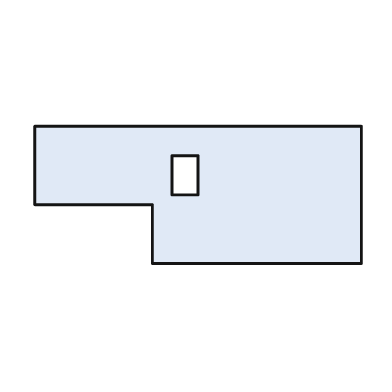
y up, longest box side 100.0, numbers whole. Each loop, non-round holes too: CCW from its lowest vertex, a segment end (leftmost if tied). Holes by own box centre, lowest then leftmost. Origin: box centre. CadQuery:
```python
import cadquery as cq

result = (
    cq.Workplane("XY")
    .moveTo(-14.0, -21.0)
    .lineTo(50.0, -21.0)
    .lineTo(50.0, 21.0)
    .lineTo(-50.0, 21.0)
    .lineTo(-50.0, -3.0)
    .lineTo(-14.0, -3.0)
    .close()
    .moveTo(-8.0, 0.0)
    .lineTo(0.0, 0.0)
    .lineTo(0.0, 12.0)
    .lineTo(-8.0, 12.0)
    .close()
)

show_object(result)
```